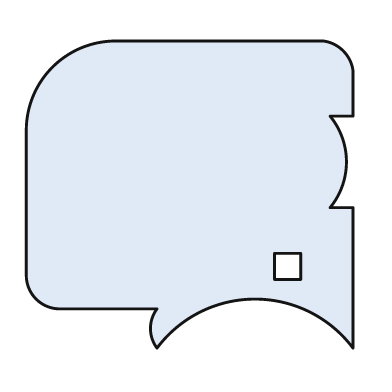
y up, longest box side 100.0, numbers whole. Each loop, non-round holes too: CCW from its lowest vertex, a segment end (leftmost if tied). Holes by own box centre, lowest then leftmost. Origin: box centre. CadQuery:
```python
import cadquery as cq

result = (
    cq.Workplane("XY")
    .moveTo(-10.0, -47.0)
    .threePointArc((20.0, -32.0), (50.0, -47.0))
    .lineTo(50.0, -4.0)
    .lineTo(43.0, -4.0)
    .threePointArc((48.0, 10.0), (43.0, 24.0))
    .lineTo(50.0, 24.0)
    .lineTo(50.0, 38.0)
    .threePointArc((47.0, 44.0), (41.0, 47.0))
    .lineTo(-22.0, 47.0)
    .threePointArc((-42.0, 39.0), (-50.0, 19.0))
    .lineTo(-50.0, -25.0)
    .threePointArc((-47.0, -32.0), (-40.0, -35.0))
    .lineTo(-10.0, -35.0)
    .threePointArc((-12.0, -41.0), (-10.0, -47.0))
    .close()
    .moveTo(26.0, -26.0)
    .lineTo(34.0, -26.0)
    .lineTo(34.0, -18.0)
    .lineTo(26.0, -18.0)
    .close()
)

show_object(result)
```